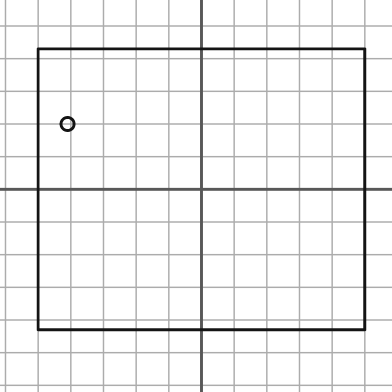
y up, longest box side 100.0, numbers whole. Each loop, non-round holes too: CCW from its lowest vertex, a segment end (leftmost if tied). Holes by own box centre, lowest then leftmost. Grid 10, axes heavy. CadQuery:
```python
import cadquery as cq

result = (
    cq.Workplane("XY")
    .moveTo(-50.0, -43.0)
    .lineTo(50.0, -43.0)
    .lineTo(50.0, 43.0)
    .lineTo(-50.0, 43.0)
    .close()
    .moveTo(-41.0, 20.0)
    .circle(2.0)
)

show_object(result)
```